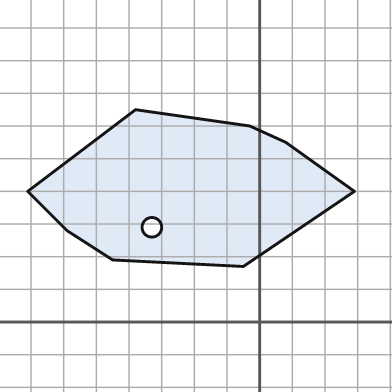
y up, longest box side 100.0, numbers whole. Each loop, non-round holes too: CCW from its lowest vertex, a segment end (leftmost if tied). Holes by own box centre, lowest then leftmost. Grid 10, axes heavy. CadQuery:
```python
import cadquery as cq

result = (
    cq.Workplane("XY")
    .moveTo(-5.0, 17.0)
    .lineTo(29.0, 40.0)
    .lineTo(8.0, 55.0)
    .lineTo(-3.0, 60.0)
    .lineTo(-38.0, 65.0)
    .lineTo(-71.0, 40.0)
    .lineTo(-59.0, 28.0)
    .lineTo(-45.0, 19.0)
    .close()
    .moveTo(-33.0, 29.0)
    .circle(3.0)
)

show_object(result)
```